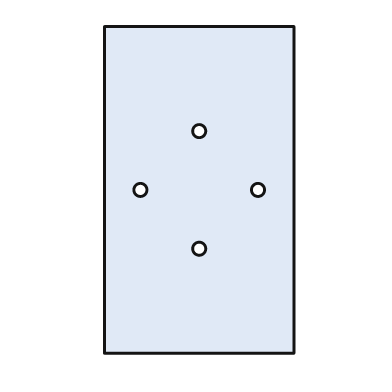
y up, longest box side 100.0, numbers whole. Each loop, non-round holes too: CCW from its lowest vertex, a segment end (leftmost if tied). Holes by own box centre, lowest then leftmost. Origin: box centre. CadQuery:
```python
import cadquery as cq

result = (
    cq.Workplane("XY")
    .moveTo(-29.0, -50.0)
    .lineTo(29.0, -50.0)
    .lineTo(29.0, 50.0)
    .lineTo(-29.0, 50.0)
    .close()
    .moveTo(0.0, -18.0)
    .circle(2.0)
    .moveTo(-18.0, 0.0)
    .circle(2.0)
    .moveTo(18.0, 0.0)
    .circle(2.0)
    .moveTo(0.0, 18.0)
    .circle(2.0)
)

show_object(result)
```